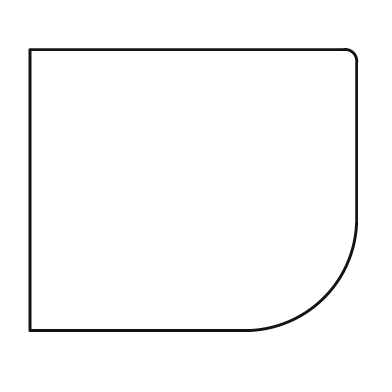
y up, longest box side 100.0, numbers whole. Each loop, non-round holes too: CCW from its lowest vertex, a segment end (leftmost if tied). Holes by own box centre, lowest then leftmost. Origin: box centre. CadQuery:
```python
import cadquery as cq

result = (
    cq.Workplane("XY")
    .moveTo(-50.0, -43.0)
    .lineTo(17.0, -43.0)
    .threePointArc((40.0, -33.0), (50.0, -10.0))
    .lineTo(50.0, 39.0)
    .threePointArc((49.0, 42.0), (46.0, 43.0))
    .lineTo(-50.0, 43.0)
    .close()
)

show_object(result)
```